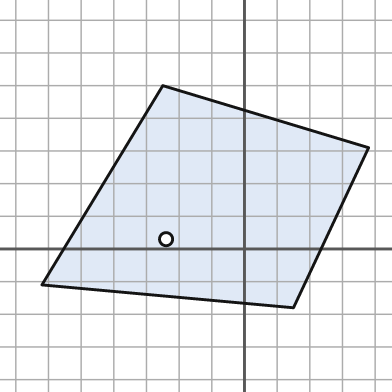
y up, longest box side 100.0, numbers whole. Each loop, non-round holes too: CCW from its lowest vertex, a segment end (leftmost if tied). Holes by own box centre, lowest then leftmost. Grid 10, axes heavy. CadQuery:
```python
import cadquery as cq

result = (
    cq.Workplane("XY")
    .moveTo(15.0, -18.0)
    .lineTo(38.0, 31.0)
    .lineTo(-25.0, 50.0)
    .lineTo(-62.0, -11.0)
    .close()
    .moveTo(-24.0, 3.0)
    .circle(2.0)
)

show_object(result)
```